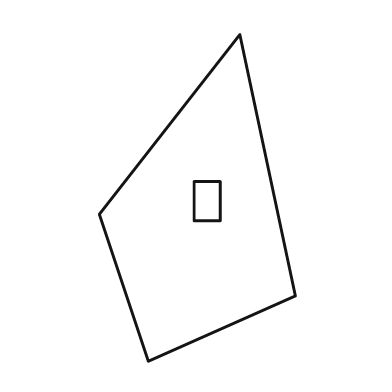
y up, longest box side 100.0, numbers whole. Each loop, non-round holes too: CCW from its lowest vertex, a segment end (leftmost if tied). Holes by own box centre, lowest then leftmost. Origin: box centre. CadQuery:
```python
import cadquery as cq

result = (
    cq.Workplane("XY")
    .moveTo(-15.0, -50.0)
    .lineTo(30.0, -30.0)
    .lineTo(13.0, 50.0)
    .lineTo(-30.0, -5.0)
    .close()
    .moveTo(-1.0, -7.0)
    .lineTo(7.0, -7.0)
    .lineTo(7.0, 5.0)
    .lineTo(-1.0, 5.0)
    .close()
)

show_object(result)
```